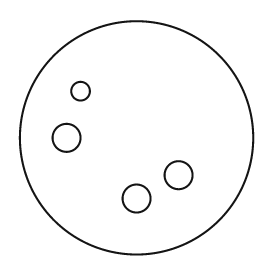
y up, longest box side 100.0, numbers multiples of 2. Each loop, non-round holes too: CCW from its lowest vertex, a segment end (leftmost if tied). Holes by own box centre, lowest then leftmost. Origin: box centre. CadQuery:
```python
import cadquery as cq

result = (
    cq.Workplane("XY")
    .moveTo(0.0, 0.0)
    .circle(50.0)
    .moveTo(0.0, -26.0)
    .circle(6.0)
    .moveTo(18.0, -16.0)
    .circle(6.0)
    .moveTo(-30.0, 0.0)
    .circle(6.0)
    .moveTo(-24.0, 20.0)
    .circle(4.0)
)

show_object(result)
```